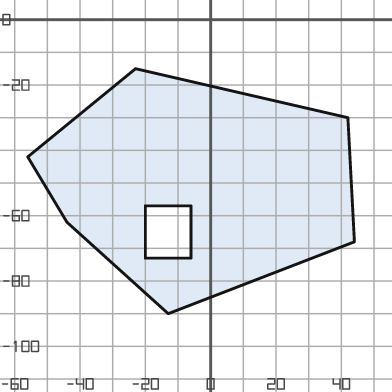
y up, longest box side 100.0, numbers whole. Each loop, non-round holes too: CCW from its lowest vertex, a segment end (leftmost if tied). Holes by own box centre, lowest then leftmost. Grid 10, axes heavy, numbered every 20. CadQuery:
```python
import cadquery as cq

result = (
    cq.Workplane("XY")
    .moveTo(-13.0, -90.0)
    .lineTo(44.0, -68.0)
    .lineTo(42.0, -30.0)
    .lineTo(-23.0, -15.0)
    .lineTo(-56.0, -42.0)
    .lineTo(-44.0, -62.0)
    .close()
    .moveTo(-20.0, -73.0)
    .lineTo(-6.0, -73.0)
    .lineTo(-6.0, -57.0)
    .lineTo(-20.0, -57.0)
    .close()
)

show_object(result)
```